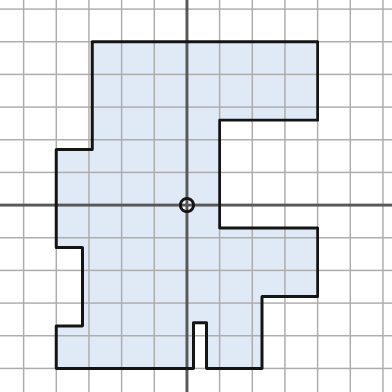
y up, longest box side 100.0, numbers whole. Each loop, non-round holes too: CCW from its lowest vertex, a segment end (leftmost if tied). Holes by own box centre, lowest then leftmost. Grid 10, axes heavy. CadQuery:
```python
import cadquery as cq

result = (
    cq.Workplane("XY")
    .moveTo(-40.0, -50.0)
    .lineTo(2.0, -50.0)
    .lineTo(2.0, -36.0)
    .lineTo(6.0, -36.0)
    .lineTo(6.0, -50.0)
    .lineTo(23.0, -50.0)
    .lineTo(23.0, -28.0)
    .lineTo(40.0, -28.0)
    .lineTo(40.0, -7.0)
    .lineTo(10.0, -7.0)
    .lineTo(10.0, 26.0)
    .lineTo(40.0, 26.0)
    .lineTo(40.0, 50.0)
    .lineTo(-29.0, 50.0)
    .lineTo(-29.0, 17.0)
    .lineTo(-40.0, 17.0)
    .lineTo(-40.0, -13.0)
    .lineTo(-32.0, -13.0)
    .lineTo(-32.0, -37.0)
    .lineTo(-40.0, -37.0)
    .close()
    .moveTo(0.0, 0.0)
    .circle(2.0)
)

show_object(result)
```